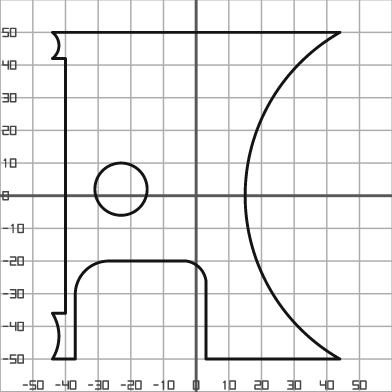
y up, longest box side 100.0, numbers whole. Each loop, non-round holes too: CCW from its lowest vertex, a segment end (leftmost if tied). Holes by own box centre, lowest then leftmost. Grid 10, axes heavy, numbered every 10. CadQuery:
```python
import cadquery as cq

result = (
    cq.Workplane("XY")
    .moveTo(-44.0, -50.0)
    .lineTo(-37.0, -50.0)
    .lineTo(-37.0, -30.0)
    .threePointArc((-34.0, -23.0), (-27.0, -20.0))
    .lineTo(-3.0, -20.0)
    .threePointArc((1.0, -22.0), (3.0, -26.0))
    .lineTo(3.0, -50.0)
    .lineTo(44.0, -50.0)
    .threePointArc((15.0, 0.0), (44.0, 50.0))
    .lineTo(-44.0, 50.0)
    .threePointArc((-42.0, 46.0), (-44.0, 42.0))
    .lineTo(-40.0, 42.0)
    .lineTo(-40.0, -36.0)
    .lineTo(-44.0, -36.0)
    .threePointArc((-42.0, -43.0), (-44.0, -50.0))
    .close()
    .moveTo(-23.0, 2.0)
    .circle(8.0)
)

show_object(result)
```